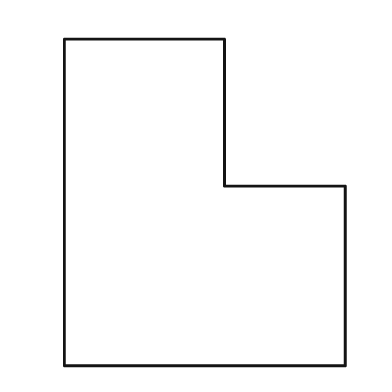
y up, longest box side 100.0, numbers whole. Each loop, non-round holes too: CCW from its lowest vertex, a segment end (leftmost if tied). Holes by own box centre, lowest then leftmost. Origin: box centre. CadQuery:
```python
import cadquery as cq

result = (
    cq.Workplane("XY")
    .moveTo(-43.0, -50.0)
    .lineTo(43.0, -50.0)
    .lineTo(43.0, 5.0)
    .lineTo(6.0, 5.0)
    .lineTo(6.0, 50.0)
    .lineTo(-43.0, 50.0)
    .close()
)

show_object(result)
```